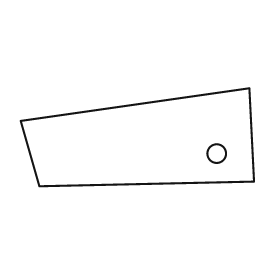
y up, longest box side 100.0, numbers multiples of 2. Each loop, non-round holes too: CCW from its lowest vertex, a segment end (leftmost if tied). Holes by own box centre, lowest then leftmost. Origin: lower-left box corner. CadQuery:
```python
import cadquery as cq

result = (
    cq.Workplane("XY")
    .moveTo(8.0, 0.0)
    .lineTo(100.0, 2.0)
    .lineTo(98.0, 42.0)
    .lineTo(0.0, 28.0)
    .close()
    .moveTo(84.0, 14.0)
    .circle(4.0)
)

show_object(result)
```